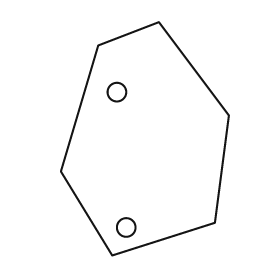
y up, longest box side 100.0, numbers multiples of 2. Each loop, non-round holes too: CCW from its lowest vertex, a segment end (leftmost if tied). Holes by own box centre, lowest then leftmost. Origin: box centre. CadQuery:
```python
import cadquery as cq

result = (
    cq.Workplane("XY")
    .moveTo(-14.0, -50.0)
    .lineTo(30.0, -36.0)
    .lineTo(36.0, 10.0)
    .lineTo(6.0, 50.0)
    .lineTo(-20.0, 40.0)
    .lineTo(-36.0, -14.0)
    .close()
    .moveTo(-8.0, -38.0)
    .circle(4.0)
    .moveTo(-12.0, 20.0)
    .circle(4.0)
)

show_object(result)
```